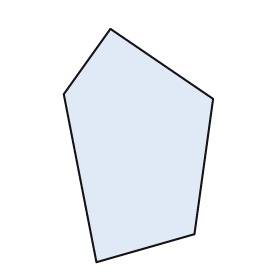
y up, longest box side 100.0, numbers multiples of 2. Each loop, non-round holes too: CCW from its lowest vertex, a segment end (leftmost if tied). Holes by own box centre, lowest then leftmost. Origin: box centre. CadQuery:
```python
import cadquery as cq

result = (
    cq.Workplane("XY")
    .moveTo(-18.0, -50.0)
    .lineTo(24.0, -38.0)
    .lineTo(32.0, 20.0)
    .lineTo(-12.0, 50.0)
    .lineTo(-32.0, 22.0)
    .close()
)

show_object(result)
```